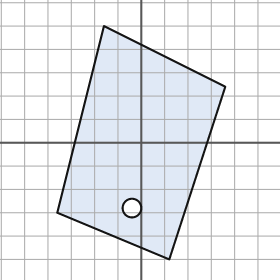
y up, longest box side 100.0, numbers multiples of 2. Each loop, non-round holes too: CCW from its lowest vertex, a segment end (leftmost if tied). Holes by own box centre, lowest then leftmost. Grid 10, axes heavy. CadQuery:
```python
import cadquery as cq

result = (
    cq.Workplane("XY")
    .moveTo(12.0, -50.0)
    .lineTo(36.0, 24.0)
    .lineTo(-16.0, 50.0)
    .lineTo(-36.0, -30.0)
    .close()
    .moveTo(-4.0, -28.0)
    .circle(4.0)
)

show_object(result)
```